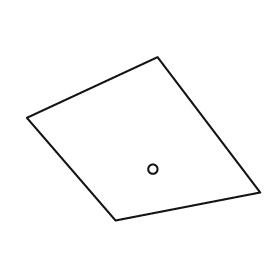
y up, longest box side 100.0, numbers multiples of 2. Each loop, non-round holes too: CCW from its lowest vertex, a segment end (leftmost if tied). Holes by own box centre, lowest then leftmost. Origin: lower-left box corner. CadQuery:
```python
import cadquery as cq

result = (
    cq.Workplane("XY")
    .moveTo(38.0, 0.0)
    .lineTo(100.0, 12.0)
    .lineTo(56.0, 70.0)
    .lineTo(0.0, 44.0)
    .close()
    .moveTo(54.0, 22.0)
    .circle(2.0)
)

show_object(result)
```